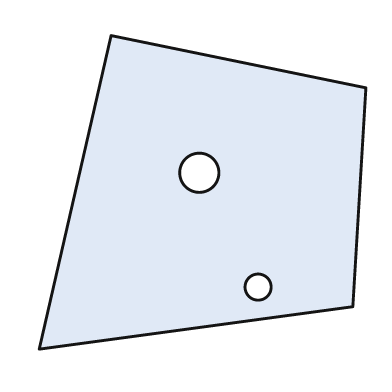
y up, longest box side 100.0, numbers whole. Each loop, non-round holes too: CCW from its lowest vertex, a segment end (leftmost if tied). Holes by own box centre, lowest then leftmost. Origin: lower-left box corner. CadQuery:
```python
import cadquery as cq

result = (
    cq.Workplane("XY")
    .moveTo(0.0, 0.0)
    .lineTo(96.0, 13.0)
    .lineTo(100.0, 80.0)
    .lineTo(22.0, 96.0)
    .close()
    .moveTo(67.0, 19.0)
    .circle(4.0)
    .moveTo(49.0, 54.0)
    .circle(6.0)
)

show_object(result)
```